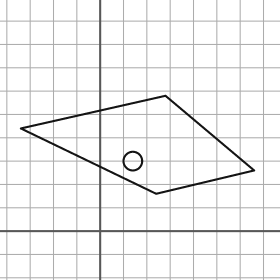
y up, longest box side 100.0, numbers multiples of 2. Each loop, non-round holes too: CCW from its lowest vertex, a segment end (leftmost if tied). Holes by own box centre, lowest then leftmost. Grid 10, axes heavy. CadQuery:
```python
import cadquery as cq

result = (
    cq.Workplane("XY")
    .moveTo(24.0, 16.0)
    .lineTo(66.0, 26.0)
    .lineTo(28.0, 58.0)
    .lineTo(-34.0, 44.0)
    .close()
    .moveTo(14.0, 30.0)
    .circle(4.0)
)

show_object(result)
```